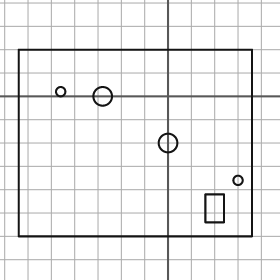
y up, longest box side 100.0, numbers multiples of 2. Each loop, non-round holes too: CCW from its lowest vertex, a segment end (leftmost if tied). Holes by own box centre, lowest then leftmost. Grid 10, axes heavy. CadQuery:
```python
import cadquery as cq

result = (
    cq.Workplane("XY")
    .moveTo(-64.0, -60.0)
    .lineTo(36.0, -60.0)
    .lineTo(36.0, 20.0)
    .lineTo(-64.0, 20.0)
    .close()
    .moveTo(16.0, -54.0)
    .lineTo(24.0, -54.0)
    .lineTo(24.0, -42.0)
    .lineTo(16.0, -42.0)
    .close()
    .moveTo(30.0, -36.0)
    .circle(2.0)
    .moveTo(0.0, -20.0)
    .circle(4.0)
    .moveTo(-28.0, 0.0)
    .circle(4.0)
    .moveTo(-46.0, 2.0)
    .circle(2.0)
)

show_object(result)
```